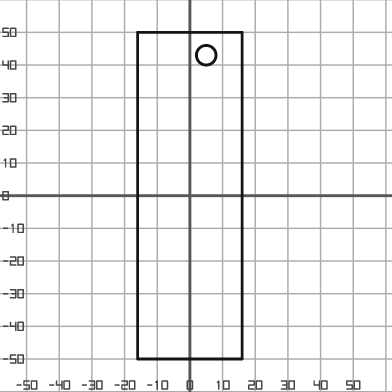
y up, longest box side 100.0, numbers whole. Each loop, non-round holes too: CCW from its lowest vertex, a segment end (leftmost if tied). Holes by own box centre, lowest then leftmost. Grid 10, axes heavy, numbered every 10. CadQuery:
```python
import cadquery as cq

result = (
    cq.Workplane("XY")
    .moveTo(-16.0, -50.0)
    .lineTo(16.0, -50.0)
    .lineTo(16.0, 50.0)
    .lineTo(-16.0, 50.0)
    .close()
    .moveTo(5.0, 43.0)
    .circle(3.0)
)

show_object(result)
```